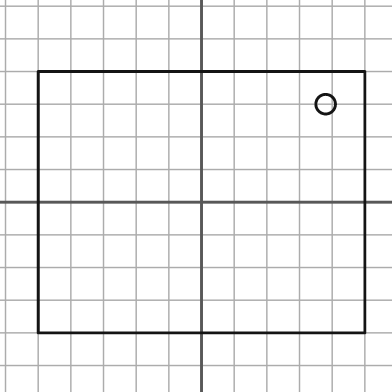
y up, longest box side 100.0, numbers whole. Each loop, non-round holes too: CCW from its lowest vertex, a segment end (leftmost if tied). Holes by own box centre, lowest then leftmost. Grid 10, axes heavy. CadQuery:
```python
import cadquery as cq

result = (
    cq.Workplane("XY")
    .moveTo(-50.0, -40.0)
    .lineTo(50.0, -40.0)
    .lineTo(50.0, 40.0)
    .lineTo(-50.0, 40.0)
    .close()
    .moveTo(38.0, 30.0)
    .circle(3.0)
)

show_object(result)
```